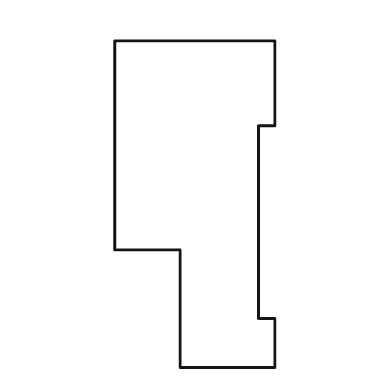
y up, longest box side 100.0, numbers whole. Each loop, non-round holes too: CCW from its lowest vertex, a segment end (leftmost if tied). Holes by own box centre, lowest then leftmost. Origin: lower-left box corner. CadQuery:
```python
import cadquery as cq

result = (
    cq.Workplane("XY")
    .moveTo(20.0, 0.0)
    .lineTo(49.0, 0.0)
    .lineTo(49.0, 15.0)
    .lineTo(44.0, 15.0)
    .lineTo(44.0, 74.0)
    .lineTo(49.0, 74.0)
    .lineTo(49.0, 100.0)
    .lineTo(0.0, 100.0)
    .lineTo(0.0, 36.0)
    .lineTo(20.0, 36.0)
    .close()
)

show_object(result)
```